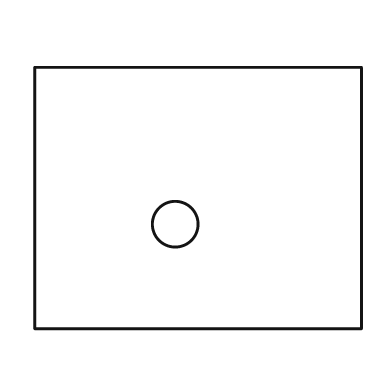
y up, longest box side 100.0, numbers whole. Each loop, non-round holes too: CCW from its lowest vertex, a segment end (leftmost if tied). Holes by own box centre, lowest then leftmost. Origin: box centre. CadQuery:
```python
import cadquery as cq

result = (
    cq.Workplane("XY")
    .moveTo(-50.0, -40.0)
    .lineTo(50.0, -40.0)
    .lineTo(50.0, 40.0)
    .lineTo(-50.0, 40.0)
    .close()
    .moveTo(-7.0, -8.0)
    .circle(7.0)
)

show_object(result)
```